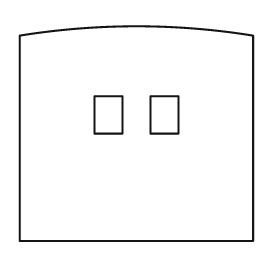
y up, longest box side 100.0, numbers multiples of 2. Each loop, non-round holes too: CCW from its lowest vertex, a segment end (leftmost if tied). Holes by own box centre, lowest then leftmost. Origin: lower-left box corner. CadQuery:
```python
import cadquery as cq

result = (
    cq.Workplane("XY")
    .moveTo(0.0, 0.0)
    .lineTo(100.0, 0.0)
    .lineTo(100.0, 88.0)
    .threePointArc((50.0, 92.0), (0.0, 88.0))
    .close()
    .moveTo(32.0, 46.0)
    .lineTo(44.0, 46.0)
    .lineTo(44.0, 62.0)
    .lineTo(32.0, 62.0)
    .close()
    .moveTo(56.0, 46.0)
    .lineTo(68.0, 46.0)
    .lineTo(68.0, 62.0)
    .lineTo(56.0, 62.0)
    .close()
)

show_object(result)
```